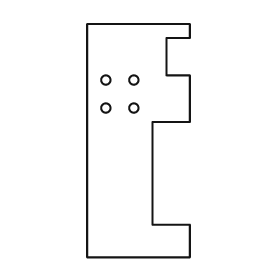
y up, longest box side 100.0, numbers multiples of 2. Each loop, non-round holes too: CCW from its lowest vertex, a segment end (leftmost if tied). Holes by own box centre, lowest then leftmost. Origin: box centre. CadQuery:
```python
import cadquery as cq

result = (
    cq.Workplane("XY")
    .moveTo(-22.0, -50.0)
    .lineTo(22.0, -50.0)
    .lineTo(22.0, -36.0)
    .lineTo(6.0, -36.0)
    .lineTo(6.0, 8.0)
    .lineTo(22.0, 8.0)
    .lineTo(22.0, 28.0)
    .lineTo(12.0, 28.0)
    .lineTo(12.0, 44.0)
    .lineTo(22.0, 44.0)
    .lineTo(22.0, 50.0)
    .lineTo(-22.0, 50.0)
    .close()
    .moveTo(-14.0, 14.0)
    .circle(2.0)
    .moveTo(-2.0, 14.0)
    .circle(2.0)
    .moveTo(-14.0, 26.0)
    .circle(2.0)
    .moveTo(-2.0, 26.0)
    .circle(2.0)
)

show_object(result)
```